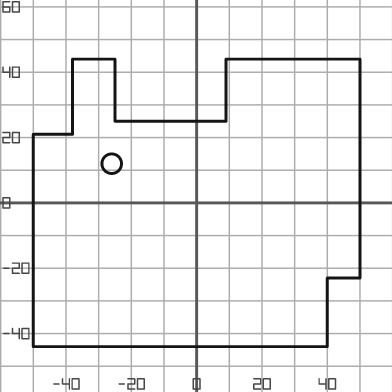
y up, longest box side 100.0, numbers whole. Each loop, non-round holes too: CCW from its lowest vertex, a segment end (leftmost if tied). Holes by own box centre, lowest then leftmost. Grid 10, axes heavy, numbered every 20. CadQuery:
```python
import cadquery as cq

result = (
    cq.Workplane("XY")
    .moveTo(-50.0, -44.0)
    .lineTo(40.0, -44.0)
    .lineTo(40.0, -23.0)
    .lineTo(50.0, -23.0)
    .lineTo(50.0, 44.0)
    .lineTo(9.0, 44.0)
    .lineTo(9.0, 25.0)
    .lineTo(-25.0, 25.0)
    .lineTo(-25.0, 44.0)
    .lineTo(-38.0, 44.0)
    .lineTo(-38.0, 21.0)
    .lineTo(-50.0, 21.0)
    .close()
    .moveTo(-26.0, 12.0)
    .circle(3.0)
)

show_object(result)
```